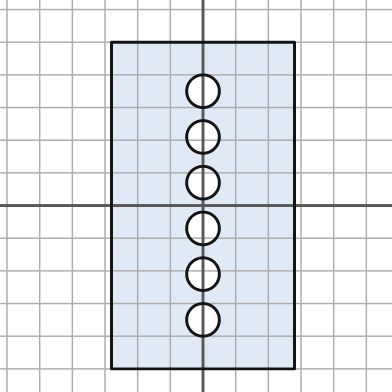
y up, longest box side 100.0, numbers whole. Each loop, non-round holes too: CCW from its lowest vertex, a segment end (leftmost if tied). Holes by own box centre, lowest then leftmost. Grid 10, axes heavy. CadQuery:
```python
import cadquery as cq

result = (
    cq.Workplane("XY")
    .moveTo(-28.0, -50.0)
    .lineTo(28.0, -50.0)
    .lineTo(28.0, 50.0)
    .lineTo(-28.0, 50.0)
    .close()
    .moveTo(0.0, -35.0)
    .circle(5.0)
    .moveTo(0.0, -21.0)
    .circle(5.0)
    .moveTo(0.0, -7.0)
    .circle(5.0)
    .moveTo(0.0, 7.0)
    .circle(5.0)
    .moveTo(0.0, 21.0)
    .circle(5.0)
    .moveTo(0.0, 35.0)
    .circle(5.0)
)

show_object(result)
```